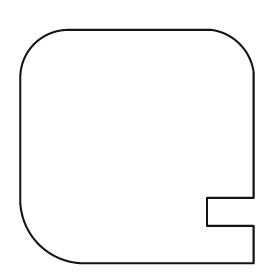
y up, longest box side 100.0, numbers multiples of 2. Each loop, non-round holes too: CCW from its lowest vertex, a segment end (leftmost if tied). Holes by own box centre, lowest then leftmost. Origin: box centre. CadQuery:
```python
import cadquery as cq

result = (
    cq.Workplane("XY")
    .moveTo(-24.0, -50.0)
    .lineTo(50.0, -50.0)
    .lineTo(50.0, -34.0)
    .lineTo(30.0, -34.0)
    .lineTo(30.0, -22.0)
    .lineTo(50.0, -22.0)
    .lineTo(50.0, 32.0)
    .threePointArc((44.0, 44.0), (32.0, 50.0))
    .lineTo(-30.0, 50.0)
    .threePointArc((-44.0, 44.0), (-50.0, 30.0))
    .lineTo(-50.0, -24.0)
    .threePointArc((-42.0, -42.0), (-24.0, -50.0))
    .close()
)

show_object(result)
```